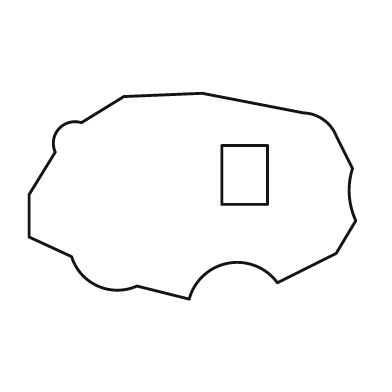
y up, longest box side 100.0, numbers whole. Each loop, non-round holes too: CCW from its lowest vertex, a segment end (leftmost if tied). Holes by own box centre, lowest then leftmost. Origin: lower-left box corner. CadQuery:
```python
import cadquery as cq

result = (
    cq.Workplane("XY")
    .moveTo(49.0, 0.0)
    .threePointArc((61.0, 11.0), (76.0, 5.0))
    .lineTo(94.0, 14.0)
    .lineTo(100.0, 24.0)
    .threePointArc((98.0, 32.0), (99.0, 40.0))
    .lineTo(94.0, 50.0)
    .threePointArc((90.0, 55.0), (84.0, 57.0))
    .lineTo(53.0, 63.0)
    .lineTo(29.0, 62.0)
    .lineTo(16.0, 54.0)
    .threePointArc((9.0, 52.0), (8.0, 45.0))
    .lineTo(0.0, 32.0)
    .lineTo(0.0, 19.0)
    .lineTo(13.0, 13.0)
    .threePointArc((21.0, 4.0), (33.0, 4.0))
    .close()
    .moveTo(59.0, 29.0)
    .lineTo(73.0, 29.0)
    .lineTo(73.0, 47.0)
    .lineTo(59.0, 47.0)
    .close()
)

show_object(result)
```